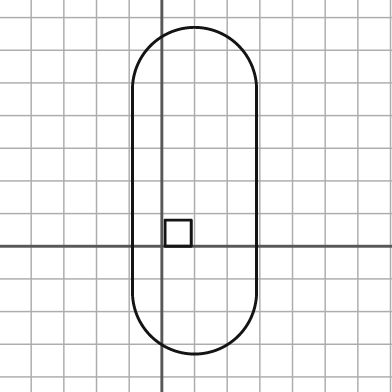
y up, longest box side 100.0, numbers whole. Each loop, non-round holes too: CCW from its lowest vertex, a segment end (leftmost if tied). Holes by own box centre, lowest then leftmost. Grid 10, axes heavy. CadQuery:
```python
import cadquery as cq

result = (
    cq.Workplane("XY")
    .moveTo(-9.0, -14.0)
    .threePointArc((10.0, -33.0), (29.0, -14.0))
    .lineTo(29.0, 48.0)
    .threePointArc((10.0, 67.0), (-9.0, 48.0))
    .close()
    .moveTo(1.0, 0.0)
    .lineTo(9.0, 0.0)
    .lineTo(9.0, 8.0)
    .lineTo(1.0, 8.0)
    .close()
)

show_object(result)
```